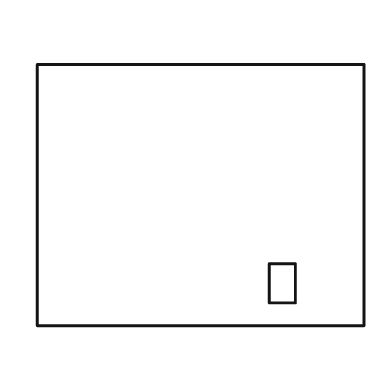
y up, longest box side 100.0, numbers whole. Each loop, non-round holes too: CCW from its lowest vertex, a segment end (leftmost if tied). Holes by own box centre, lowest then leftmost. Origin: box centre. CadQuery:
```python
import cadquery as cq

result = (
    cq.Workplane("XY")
    .moveTo(-50.0, -40.0)
    .lineTo(50.0, -40.0)
    .lineTo(50.0, 40.0)
    .lineTo(-50.0, 40.0)
    .close()
    .moveTo(21.0, -33.0)
    .lineTo(29.0, -33.0)
    .lineTo(29.0, -21.0)
    .lineTo(21.0, -21.0)
    .close()
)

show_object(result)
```